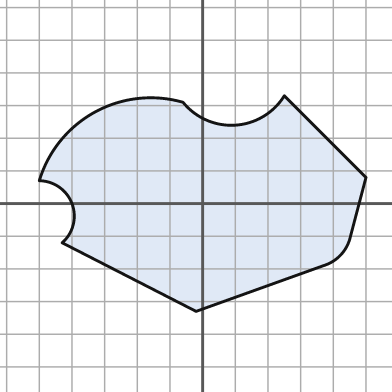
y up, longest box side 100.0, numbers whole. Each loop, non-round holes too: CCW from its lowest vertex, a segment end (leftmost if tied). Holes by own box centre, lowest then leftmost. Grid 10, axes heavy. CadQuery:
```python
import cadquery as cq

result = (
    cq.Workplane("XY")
    .moveTo(-2.0, -33.0)
    .lineTo(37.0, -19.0)
    .threePointArc((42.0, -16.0), (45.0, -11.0))
    .lineTo(50.0, 8.0)
    .lineTo(25.0, 33.0)
    .threePointArc((10.0, 24.0), (-6.0, 31.0))
    .threePointArc((-33.0, 28.0), (-50.0, 7.0))
    .threePointArc((-40.0, 0.0), (-43.0, -12.0))
    .close()
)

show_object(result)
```